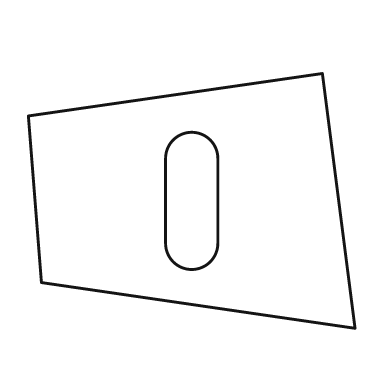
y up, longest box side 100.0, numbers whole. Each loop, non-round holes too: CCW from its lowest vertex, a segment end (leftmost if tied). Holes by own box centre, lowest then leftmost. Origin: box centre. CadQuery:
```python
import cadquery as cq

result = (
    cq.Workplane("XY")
    .moveTo(50.0, -39.0)
    .lineTo(40.0, 39.0)
    .lineTo(-50.0, 26.0)
    .lineTo(-46.0, -25.0)
    .close()
    .moveTo(-8.0, -13.0)
    .threePointArc((0.0, -21.0), (8.0, -13.0))
    .lineTo(8.0, 13.0)
    .threePointArc((0.0, 21.0), (-8.0, 13.0))
    .close()
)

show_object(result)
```